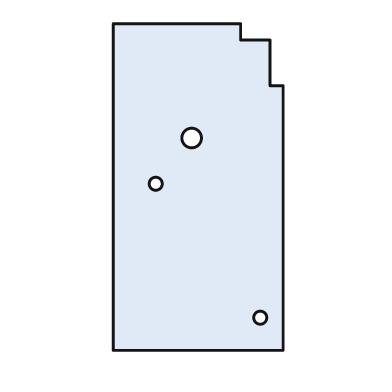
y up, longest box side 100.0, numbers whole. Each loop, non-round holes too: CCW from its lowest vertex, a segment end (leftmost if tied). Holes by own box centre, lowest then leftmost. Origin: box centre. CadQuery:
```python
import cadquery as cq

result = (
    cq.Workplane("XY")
    .moveTo(-26.0, -50.0)
    .lineTo(26.0, -50.0)
    .lineTo(26.0, 31.0)
    .lineTo(22.0, 31.0)
    .lineTo(22.0, 45.0)
    .lineTo(13.0, 45.0)
    .lineTo(13.0, 50.0)
    .lineTo(-26.0, 50.0)
    .close()
    .moveTo(19.0, -40.0)
    .circle(2.0)
    .moveTo(-13.0, 1.0)
    .circle(2.0)
    .moveTo(-2.0, 15.0)
    .circle(3.0)
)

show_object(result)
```